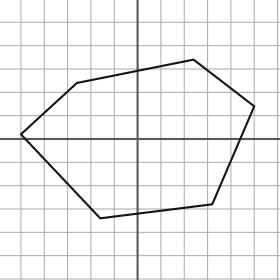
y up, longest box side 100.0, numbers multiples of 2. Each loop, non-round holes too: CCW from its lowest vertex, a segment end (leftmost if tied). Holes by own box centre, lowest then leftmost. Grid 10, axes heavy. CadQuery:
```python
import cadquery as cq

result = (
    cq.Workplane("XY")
    .moveTo(-16.0, -34.0)
    .lineTo(32.0, -28.0)
    .lineTo(50.0, 14.0)
    .lineTo(24.0, 34.0)
    .lineTo(-26.0, 24.0)
    .lineTo(-50.0, 2.0)
    .close()
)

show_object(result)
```